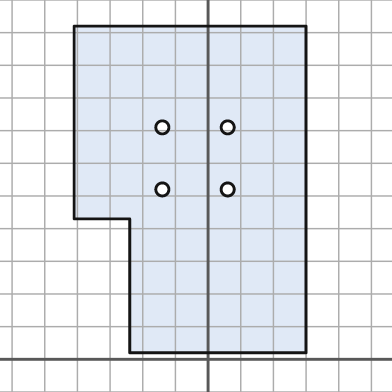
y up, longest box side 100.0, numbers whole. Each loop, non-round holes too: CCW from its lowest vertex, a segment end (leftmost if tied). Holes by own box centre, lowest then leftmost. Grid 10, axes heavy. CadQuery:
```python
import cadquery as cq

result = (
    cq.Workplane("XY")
    .moveTo(-24.0, 2.0)
    .lineTo(30.0, 2.0)
    .lineTo(30.0, 102.0)
    .lineTo(-41.0, 102.0)
    .lineTo(-41.0, 43.0)
    .lineTo(-24.0, 43.0)
    .close()
    .moveTo(-14.0, 52.0)
    .circle(2.0)
    .moveTo(6.0, 52.0)
    .circle(2.0)
    .moveTo(-14.0, 71.0)
    .circle(2.0)
    .moveTo(6.0, 71.0)
    .circle(2.0)
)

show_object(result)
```